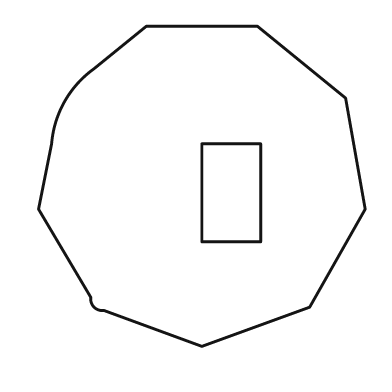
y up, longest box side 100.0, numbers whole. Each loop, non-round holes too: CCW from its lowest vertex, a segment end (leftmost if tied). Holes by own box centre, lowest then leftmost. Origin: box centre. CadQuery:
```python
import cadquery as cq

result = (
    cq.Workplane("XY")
    .moveTo(0.0, -49.0)
    .lineTo(33.0, -37.0)
    .lineTo(50.0, -7.0)
    .lineTo(44.0, 27.0)
    .lineTo(17.0, 49.0)
    .lineTo(-17.0, 49.0)
    .lineTo(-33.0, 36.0)
    .threePointArc((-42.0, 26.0), (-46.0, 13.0))
    .lineTo(-50.0, -7.0)
    .lineTo(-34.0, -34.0)
    .threePointArc((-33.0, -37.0), (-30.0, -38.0))
    .close()
    .moveTo(0.0, -17.0)
    .lineTo(18.0, -17.0)
    .lineTo(18.0, 13.0)
    .lineTo(0.0, 13.0)
    .close()
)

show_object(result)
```